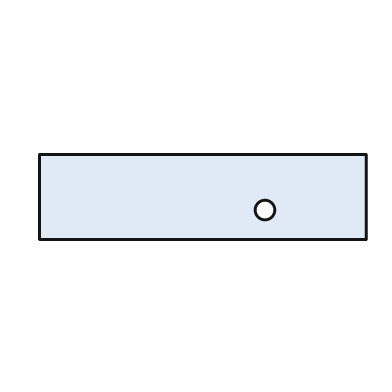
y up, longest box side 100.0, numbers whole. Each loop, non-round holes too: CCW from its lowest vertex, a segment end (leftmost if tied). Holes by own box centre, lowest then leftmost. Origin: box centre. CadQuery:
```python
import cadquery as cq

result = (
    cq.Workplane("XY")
    .moveTo(-50.0, -13.0)
    .lineTo(50.0, -13.0)
    .lineTo(50.0, 13.0)
    .lineTo(-50.0, 13.0)
    .close()
    .moveTo(19.0, -4.0)
    .circle(3.0)
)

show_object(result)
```